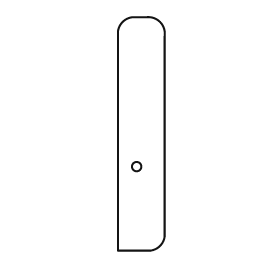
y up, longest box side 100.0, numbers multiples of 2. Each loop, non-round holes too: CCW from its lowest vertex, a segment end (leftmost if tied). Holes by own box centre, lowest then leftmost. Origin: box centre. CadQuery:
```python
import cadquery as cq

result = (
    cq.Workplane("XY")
    .moveTo(-10.0, -50.0)
    .lineTo(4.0, -50.0)
    .threePointArc((8.0, -48.0), (10.0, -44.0))
    .lineTo(10.0, 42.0)
    .threePointArc((8.0, 48.0), (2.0, 50.0))
    .lineTo(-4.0, 50.0)
    .threePointArc((-8.0, 48.0), (-10.0, 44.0))
    .close()
    .moveTo(-2.0, -14.0)
    .circle(2.0)
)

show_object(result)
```